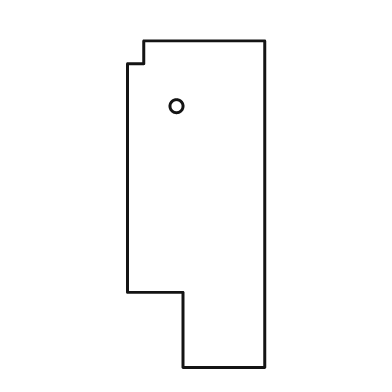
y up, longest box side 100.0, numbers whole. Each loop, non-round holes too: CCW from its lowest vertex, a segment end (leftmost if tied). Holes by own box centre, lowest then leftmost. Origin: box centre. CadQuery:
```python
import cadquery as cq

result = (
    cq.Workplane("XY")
    .moveTo(-4.0, -50.0)
    .lineTo(21.0, -50.0)
    .lineTo(21.0, 50.0)
    .lineTo(-16.0, 50.0)
    .lineTo(-16.0, 43.0)
    .lineTo(-21.0, 43.0)
    .lineTo(-21.0, -27.0)
    .lineTo(-4.0, -27.0)
    .close()
    .moveTo(-6.0, 30.0)
    .circle(2.0)
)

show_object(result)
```